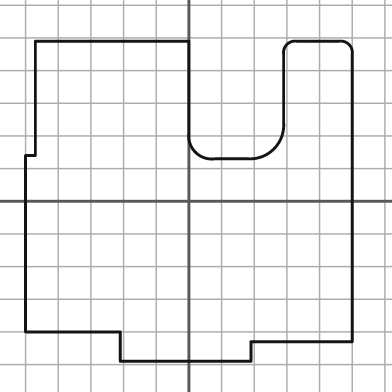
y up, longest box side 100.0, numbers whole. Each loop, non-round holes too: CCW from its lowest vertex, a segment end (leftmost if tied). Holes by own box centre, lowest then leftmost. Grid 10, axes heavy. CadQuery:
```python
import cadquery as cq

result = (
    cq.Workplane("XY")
    .moveTo(-21.0, -49.0)
    .lineTo(19.0, -49.0)
    .lineTo(19.0, -43.0)
    .lineTo(50.0, -43.0)
    .lineTo(50.0, 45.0)
    .threePointArc((49.0, 48.0), (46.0, 49.0))
    .lineTo(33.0, 49.0)
    .threePointArc((30.0, 48.0), (29.0, 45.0))
    .lineTo(29.0, 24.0)
    .threePointArc((26.0, 16.0), (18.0, 13.0))
    .lineTo(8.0, 13.0)
    .threePointArc((2.0, 15.0), (0.0, 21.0))
    .lineTo(0.0, 49.0)
    .lineTo(-47.0, 49.0)
    .lineTo(-47.0, 14.0)
    .lineTo(-50.0, 14.0)
    .lineTo(-50.0, -40.0)
    .lineTo(-21.0, -40.0)
    .close()
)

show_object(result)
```